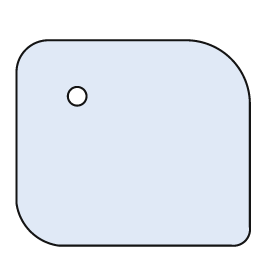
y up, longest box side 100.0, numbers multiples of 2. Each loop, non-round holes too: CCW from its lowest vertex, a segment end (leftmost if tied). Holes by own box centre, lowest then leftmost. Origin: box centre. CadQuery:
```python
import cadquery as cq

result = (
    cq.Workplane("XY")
    .moveTo(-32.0, -44.0)
    .lineTo(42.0, -44.0)
    .threePointArc((48.0, -42.0), (50.0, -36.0))
    .lineTo(50.0, 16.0)
    .threePointArc((42.0, 36.0), (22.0, 44.0))
    .lineTo(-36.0, 44.0)
    .threePointArc((-46.0, 40.0), (-50.0, 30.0))
    .lineTo(-50.0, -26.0)
    .threePointArc((-44.0, -38.0), (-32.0, -44.0))
    .close()
    .moveTo(-24.0, 20.0)
    .circle(4.0)
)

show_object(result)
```